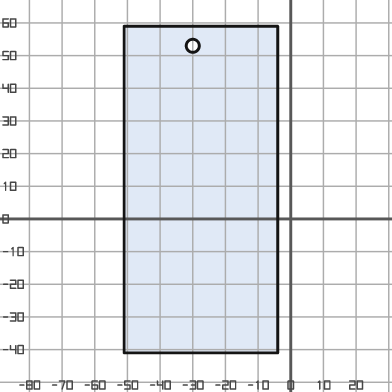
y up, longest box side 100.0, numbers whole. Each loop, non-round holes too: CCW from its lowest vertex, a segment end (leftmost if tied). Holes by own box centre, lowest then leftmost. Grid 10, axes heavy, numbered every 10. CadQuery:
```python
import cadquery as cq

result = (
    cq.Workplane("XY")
    .moveTo(-51.0, -41.0)
    .lineTo(-4.0, -41.0)
    .lineTo(-4.0, 59.0)
    .lineTo(-51.0, 59.0)
    .close()
    .moveTo(-30.0, 53.0)
    .circle(2.0)
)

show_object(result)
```